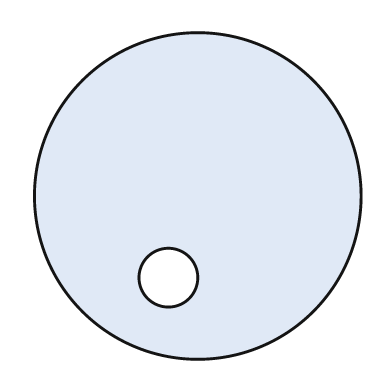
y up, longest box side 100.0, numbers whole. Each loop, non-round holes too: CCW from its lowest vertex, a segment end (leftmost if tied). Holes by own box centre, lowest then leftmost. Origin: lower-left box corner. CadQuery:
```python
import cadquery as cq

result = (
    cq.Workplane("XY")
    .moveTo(50.0, 50.0)
    .circle(50.0)
    .moveTo(41.0, 25.0)
    .circle(9.0)
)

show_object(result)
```